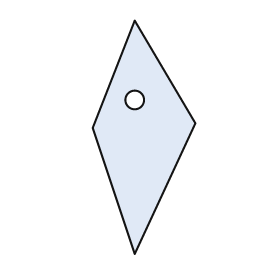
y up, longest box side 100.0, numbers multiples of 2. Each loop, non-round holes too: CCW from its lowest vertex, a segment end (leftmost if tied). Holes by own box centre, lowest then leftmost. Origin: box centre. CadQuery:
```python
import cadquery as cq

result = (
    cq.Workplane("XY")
    .moveTo(-4.0, -50.0)
    .lineTo(22.0, 6.0)
    .lineTo(-4.0, 50.0)
    .lineTo(-22.0, 4.0)
    .close()
    .moveTo(-4.0, 16.0)
    .circle(4.0)
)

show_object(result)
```